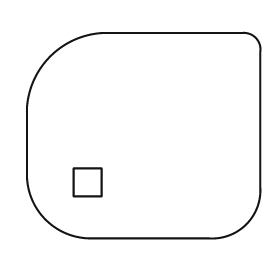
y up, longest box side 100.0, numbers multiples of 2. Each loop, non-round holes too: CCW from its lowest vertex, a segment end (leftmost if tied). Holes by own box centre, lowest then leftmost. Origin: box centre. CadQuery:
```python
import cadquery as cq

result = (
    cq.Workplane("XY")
    .moveTo(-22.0, -44.0)
    .lineTo(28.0, -44.0)
    .threePointArc((44.0, -38.0), (50.0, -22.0))
    .lineTo(50.0, 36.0)
    .threePointArc((48.0, 42.0), (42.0, 44.0))
    .lineTo(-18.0, 44.0)
    .threePointArc((-40.0, 34.0), (-50.0, 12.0))
    .lineTo(-50.0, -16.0)
    .threePointArc((-42.0, -36.0), (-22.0, -44.0))
    .close()
    .moveTo(-30.0, -26.0)
    .lineTo(-18.0, -26.0)
    .lineTo(-18.0, -14.0)
    .lineTo(-30.0, -14.0)
    .close()
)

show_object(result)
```